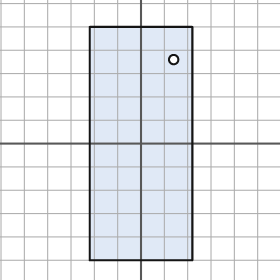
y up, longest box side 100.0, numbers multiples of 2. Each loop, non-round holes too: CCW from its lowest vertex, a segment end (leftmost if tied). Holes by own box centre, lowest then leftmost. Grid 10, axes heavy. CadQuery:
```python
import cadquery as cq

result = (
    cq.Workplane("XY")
    .moveTo(-22.0, -50.0)
    .lineTo(22.0, -50.0)
    .lineTo(22.0, 50.0)
    .lineTo(-22.0, 50.0)
    .close()
    .moveTo(14.0, 36.0)
    .circle(2.0)
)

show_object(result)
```